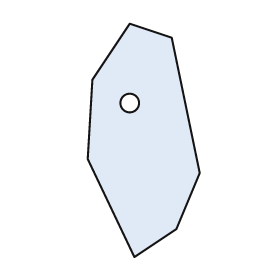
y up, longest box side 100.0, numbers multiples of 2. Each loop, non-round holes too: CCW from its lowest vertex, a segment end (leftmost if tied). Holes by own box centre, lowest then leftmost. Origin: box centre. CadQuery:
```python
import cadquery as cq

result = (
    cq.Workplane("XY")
    .moveTo(-4.0, -50.0)
    .lineTo(14.0, -38.0)
    .lineTo(24.0, -14.0)
    .lineTo(12.0, 44.0)
    .lineTo(-6.0, 50.0)
    .lineTo(-22.0, 26.0)
    .lineTo(-24.0, -8.0)
    .close()
    .moveTo(-6.0, 16.0)
    .circle(4.0)
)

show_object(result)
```